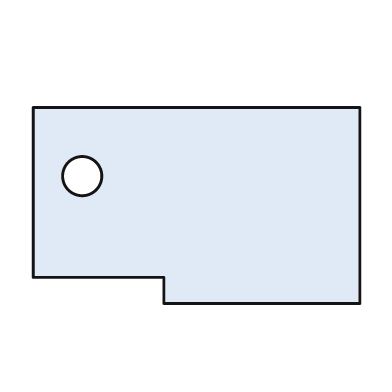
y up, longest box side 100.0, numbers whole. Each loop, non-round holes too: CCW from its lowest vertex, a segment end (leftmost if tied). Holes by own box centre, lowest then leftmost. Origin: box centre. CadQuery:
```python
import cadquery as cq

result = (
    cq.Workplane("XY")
    .moveTo(-10.0, -30.0)
    .lineTo(50.0, -30.0)
    .lineTo(50.0, 30.0)
    .lineTo(-50.0, 30.0)
    .lineTo(-50.0, -22.0)
    .lineTo(-10.0, -22.0)
    .close()
    .moveTo(-35.0, 9.0)
    .circle(6.0)
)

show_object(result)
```